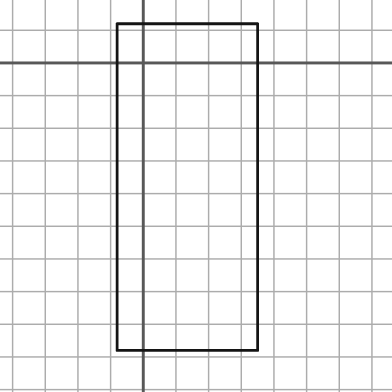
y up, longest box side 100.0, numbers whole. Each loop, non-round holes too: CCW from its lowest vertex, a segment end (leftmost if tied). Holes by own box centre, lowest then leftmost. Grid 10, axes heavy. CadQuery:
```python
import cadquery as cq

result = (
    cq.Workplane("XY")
    .moveTo(-8.0, -88.0)
    .lineTo(35.0, -88.0)
    .lineTo(35.0, 12.0)
    .lineTo(-8.0, 12.0)
    .close()
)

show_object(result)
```